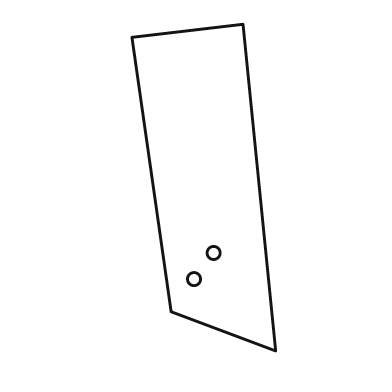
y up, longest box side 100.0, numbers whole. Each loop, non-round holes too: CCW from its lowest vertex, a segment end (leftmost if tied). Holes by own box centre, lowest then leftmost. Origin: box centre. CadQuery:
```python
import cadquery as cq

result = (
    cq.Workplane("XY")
    .moveTo(22.0, -50.0)
    .lineTo(12.0, 50.0)
    .lineTo(-22.0, 46.0)
    .lineTo(-10.0, -38.0)
    .close()
    .moveTo(-3.0, -28.0)
    .circle(2.0)
    .moveTo(3.0, -20.0)
    .circle(2.0)
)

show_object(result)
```